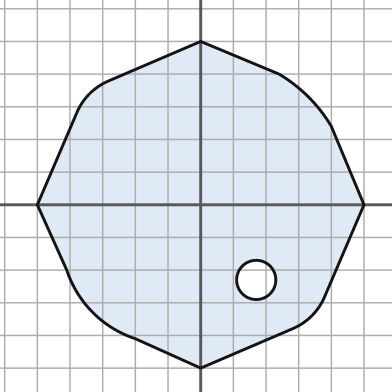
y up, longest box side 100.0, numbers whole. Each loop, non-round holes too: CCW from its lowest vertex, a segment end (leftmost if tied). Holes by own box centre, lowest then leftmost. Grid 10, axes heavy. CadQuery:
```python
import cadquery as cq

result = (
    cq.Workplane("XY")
    .moveTo(0.0, -50.0)
    .lineTo(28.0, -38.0)
    .threePointArc((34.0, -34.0), (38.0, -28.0))
    .lineTo(50.0, 0.0)
    .lineTo(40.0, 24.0)
    .threePointArc((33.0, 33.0), (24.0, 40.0))
    .lineTo(0.0, 50.0)
    .lineTo(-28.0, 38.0)
    .threePointArc((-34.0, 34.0), (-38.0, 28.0))
    .lineTo(-50.0, 0.0)
    .lineTo(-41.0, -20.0)
    .threePointArc((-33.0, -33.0), (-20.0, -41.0))
    .close()
    .moveTo(17.0, -23.0)
    .circle(6.0)
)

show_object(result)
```